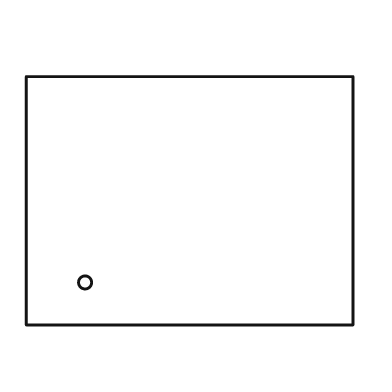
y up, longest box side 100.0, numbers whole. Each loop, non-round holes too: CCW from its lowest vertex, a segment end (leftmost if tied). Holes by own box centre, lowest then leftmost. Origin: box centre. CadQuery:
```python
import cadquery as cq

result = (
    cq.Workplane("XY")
    .moveTo(-50.0, -38.0)
    .lineTo(50.0, -38.0)
    .lineTo(50.0, 38.0)
    .lineTo(-50.0, 38.0)
    .close()
    .moveTo(-32.0, -25.0)
    .circle(2.0)
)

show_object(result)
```